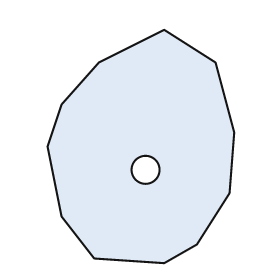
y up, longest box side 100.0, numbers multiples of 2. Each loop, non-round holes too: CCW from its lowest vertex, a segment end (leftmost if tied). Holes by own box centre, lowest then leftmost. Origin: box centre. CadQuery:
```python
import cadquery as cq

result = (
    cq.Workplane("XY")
    .moveTo(10.0, -50.0)
    .lineTo(24.0, -42.0)
    .lineTo(38.0, -20.0)
    .lineTo(40.0, 6.0)
    .lineTo(32.0, 36.0)
    .lineTo(10.0, 50.0)
    .lineTo(-18.0, 36.0)
    .lineTo(-34.0, 18.0)
    .lineTo(-40.0, 0.0)
    .lineTo(-34.0, -30.0)
    .lineTo(-20.0, -48.0)
    .close()
    .moveTo(2.0, -10.0)
    .circle(6.0)
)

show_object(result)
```